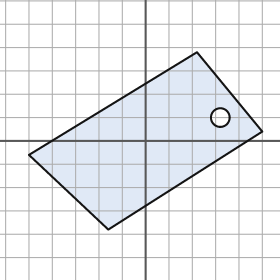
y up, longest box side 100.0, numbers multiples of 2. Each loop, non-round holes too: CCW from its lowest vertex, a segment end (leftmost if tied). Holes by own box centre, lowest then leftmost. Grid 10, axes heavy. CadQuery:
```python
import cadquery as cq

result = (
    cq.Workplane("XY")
    .moveTo(-16.0, -38.0)
    .lineTo(50.0, 4.0)
    .lineTo(22.0, 38.0)
    .lineTo(-50.0, -6.0)
    .close()
    .moveTo(32.0, 10.0)
    .circle(4.0)
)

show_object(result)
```